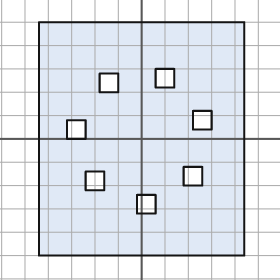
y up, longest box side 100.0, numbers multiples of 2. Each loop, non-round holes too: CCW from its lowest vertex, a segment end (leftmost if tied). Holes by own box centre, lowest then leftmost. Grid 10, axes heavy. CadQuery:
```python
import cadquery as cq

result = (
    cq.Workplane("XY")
    .moveTo(-44.0, -50.0)
    .lineTo(44.0, -50.0)
    .lineTo(44.0, 50.0)
    .lineTo(-44.0, 50.0)
    .close()
    .moveTo(-2.0, -32.0)
    .lineTo(6.0, -32.0)
    .lineTo(6.0, -24.0)
    .lineTo(-2.0, -24.0)
    .close()
    .moveTo(-24.0, -22.0)
    .lineTo(-16.0, -22.0)
    .lineTo(-16.0, -14.0)
    .lineTo(-24.0, -14.0)
    .close()
    .moveTo(18.0, -20.0)
    .lineTo(26.0, -20.0)
    .lineTo(26.0, -12.0)
    .lineTo(18.0, -12.0)
    .close()
    .moveTo(-32.0, 0.0)
    .lineTo(-24.0, 0.0)
    .lineTo(-24.0, 8.0)
    .lineTo(-32.0, 8.0)
    .close()
    .moveTo(22.0, 4.0)
    .lineTo(30.0, 4.0)
    .lineTo(30.0, 12.0)
    .lineTo(22.0, 12.0)
    .close()
    .moveTo(-18.0, 20.0)
    .lineTo(-10.0, 20.0)
    .lineTo(-10.0, 28.0)
    .lineTo(-18.0, 28.0)
    .close()
    .moveTo(6.0, 22.0)
    .lineTo(14.0, 22.0)
    .lineTo(14.0, 30.0)
    .lineTo(6.0, 30.0)
    .close()
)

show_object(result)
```